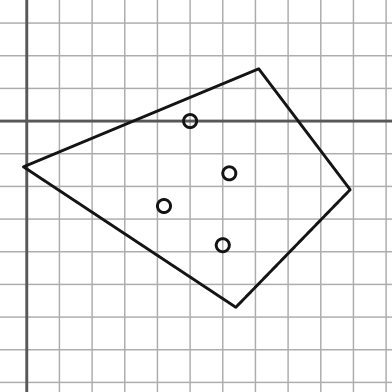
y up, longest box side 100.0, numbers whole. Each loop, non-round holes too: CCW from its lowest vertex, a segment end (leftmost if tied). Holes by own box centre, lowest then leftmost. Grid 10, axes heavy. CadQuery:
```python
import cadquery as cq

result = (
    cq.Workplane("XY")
    .moveTo(64.0, -57.0)
    .lineTo(99.0, -21.0)
    .lineTo(71.0, 16.0)
    .lineTo(-1.0, -14.0)
    .close()
    .moveTo(60.0, -38.0)
    .circle(2.0)
    .moveTo(42.0, -26.0)
    .circle(2.0)
    .moveTo(62.0, -16.0)
    .circle(2.0)
    .moveTo(50.0, 0.0)
    .circle(2.0)
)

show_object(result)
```